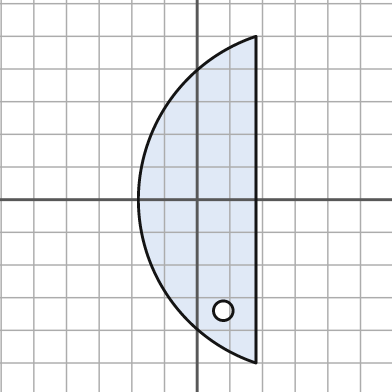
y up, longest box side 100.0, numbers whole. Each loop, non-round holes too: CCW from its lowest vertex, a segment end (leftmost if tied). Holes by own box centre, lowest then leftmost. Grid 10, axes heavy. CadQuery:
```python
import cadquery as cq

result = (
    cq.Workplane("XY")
    .moveTo(18.0, -50.0)
    .lineTo(18.0, 50.0)
    .threePointArc((-18.0, 0.0), (18.0, -50.0))
    .close()
    .moveTo(8.0, -34.0)
    .circle(3.0)
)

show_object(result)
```